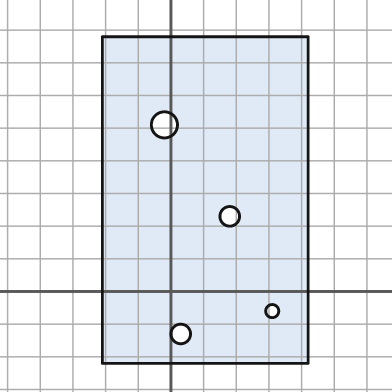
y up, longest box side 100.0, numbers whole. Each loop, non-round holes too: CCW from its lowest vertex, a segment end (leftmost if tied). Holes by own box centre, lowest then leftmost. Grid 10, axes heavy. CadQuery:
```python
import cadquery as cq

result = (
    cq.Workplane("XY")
    .moveTo(-21.0, -22.0)
    .lineTo(42.0, -22.0)
    .lineTo(42.0, 78.0)
    .lineTo(-21.0, 78.0)
    .close()
    .moveTo(3.0, -13.0)
    .circle(3.0)
    .moveTo(31.0, -6.0)
    .circle(2.0)
    .moveTo(18.0, 23.0)
    .circle(3.0)
    .moveTo(-2.0, 51.0)
    .circle(4.0)
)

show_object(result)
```